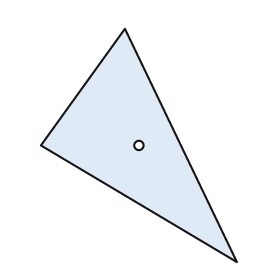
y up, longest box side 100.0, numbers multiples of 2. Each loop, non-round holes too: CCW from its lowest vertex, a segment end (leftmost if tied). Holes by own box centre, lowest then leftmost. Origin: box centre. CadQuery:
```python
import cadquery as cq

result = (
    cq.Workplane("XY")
    .moveTo(42.0, -50.0)
    .lineTo(-6.0, 50.0)
    .lineTo(-42.0, 0.0)
    .close()
    .moveTo(0.0, 0.0)
    .circle(2.0)
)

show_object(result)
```